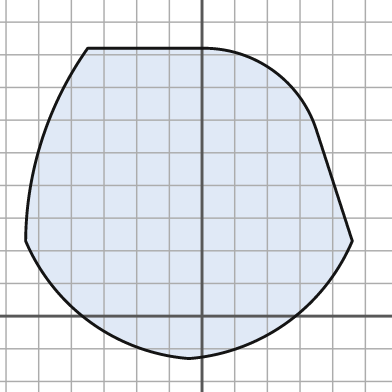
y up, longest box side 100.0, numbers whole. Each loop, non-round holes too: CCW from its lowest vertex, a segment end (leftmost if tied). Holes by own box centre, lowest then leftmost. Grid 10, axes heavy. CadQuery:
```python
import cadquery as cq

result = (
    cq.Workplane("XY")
    .moveTo(-4.0, -13.0)
    .threePointArc((26.0, -2.0), (46.0, 23.0))
    .lineTo(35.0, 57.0)
    .threePointArc((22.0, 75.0), (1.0, 82.0))
    .lineTo(-35.0, 82.0)
    .threePointArc((-49.0, 54.0), (-54.0, 23.0))
    .threePointArc((-34.0, -2.0), (-4.0, -13.0))
    .close()
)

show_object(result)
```